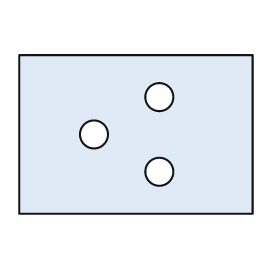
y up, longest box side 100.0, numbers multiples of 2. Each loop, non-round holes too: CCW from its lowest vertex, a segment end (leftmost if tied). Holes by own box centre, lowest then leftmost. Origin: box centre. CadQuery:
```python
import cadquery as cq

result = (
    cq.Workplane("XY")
    .moveTo(-50.0, -34.0)
    .lineTo(50.0, -34.0)
    .lineTo(50.0, 34.0)
    .lineTo(-50.0, 34.0)
    .close()
    .moveTo(10.0, -16.0)
    .circle(6.0)
    .moveTo(-18.0, 0.0)
    .circle(6.0)
    .moveTo(10.0, 16.0)
    .circle(6.0)
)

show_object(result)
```